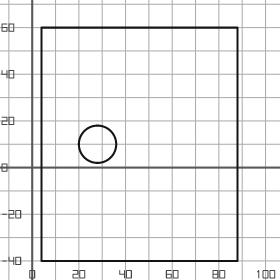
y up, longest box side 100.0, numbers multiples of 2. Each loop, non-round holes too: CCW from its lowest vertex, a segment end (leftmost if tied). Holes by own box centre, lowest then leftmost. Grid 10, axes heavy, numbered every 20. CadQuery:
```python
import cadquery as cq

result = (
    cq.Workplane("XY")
    .moveTo(4.0, -40.0)
    .lineTo(88.0, -40.0)
    .lineTo(88.0, 60.0)
    .lineTo(4.0, 60.0)
    .close()
    .moveTo(28.0, 10.0)
    .circle(8.0)
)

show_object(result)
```